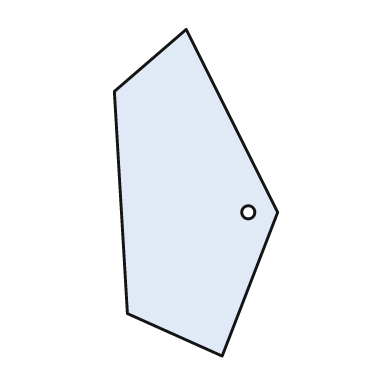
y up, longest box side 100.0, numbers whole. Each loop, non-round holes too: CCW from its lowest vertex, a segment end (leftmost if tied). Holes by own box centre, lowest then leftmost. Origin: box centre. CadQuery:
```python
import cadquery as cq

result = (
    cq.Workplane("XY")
    .moveTo(8.0, -50.0)
    .lineTo(25.0, -6.0)
    .lineTo(-3.0, 50.0)
    .lineTo(-25.0, 31.0)
    .lineTo(-21.0, -37.0)
    .close()
    .moveTo(16.0, -6.0)
    .circle(2.0)
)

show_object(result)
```